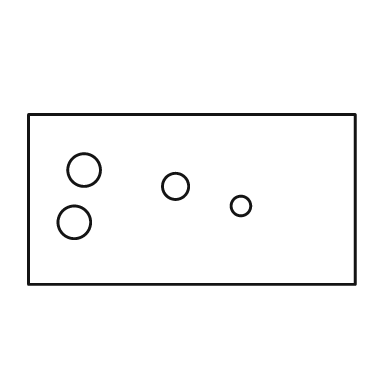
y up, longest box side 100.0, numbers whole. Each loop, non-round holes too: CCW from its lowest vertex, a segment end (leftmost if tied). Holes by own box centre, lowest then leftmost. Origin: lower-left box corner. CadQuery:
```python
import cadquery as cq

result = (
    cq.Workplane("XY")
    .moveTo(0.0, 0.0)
    .lineTo(100.0, 0.0)
    .lineTo(100.0, 52.0)
    .lineTo(0.0, 52.0)
    .close()
    .moveTo(14.0, 19.0)
    .circle(5.0)
    .moveTo(65.0, 24.0)
    .circle(3.0)
    .moveTo(45.0, 30.0)
    .circle(4.0)
    .moveTo(17.0, 35.0)
    .circle(5.0)
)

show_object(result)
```